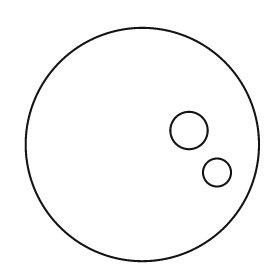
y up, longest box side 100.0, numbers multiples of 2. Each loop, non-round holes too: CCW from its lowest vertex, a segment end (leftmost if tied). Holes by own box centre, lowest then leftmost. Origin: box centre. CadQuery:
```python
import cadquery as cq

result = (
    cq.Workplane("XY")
    .moveTo(0.0, 0.0)
    .circle(50.0)
    .moveTo(32.0, -12.0)
    .circle(6.0)
    .moveTo(20.0, 6.0)
    .circle(8.0)
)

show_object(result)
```